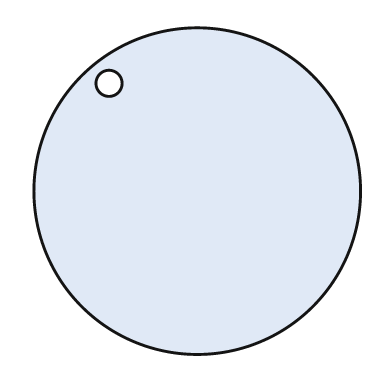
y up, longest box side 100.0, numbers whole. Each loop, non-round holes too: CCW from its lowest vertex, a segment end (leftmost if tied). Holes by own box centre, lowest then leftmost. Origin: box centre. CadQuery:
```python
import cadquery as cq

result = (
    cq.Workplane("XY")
    .moveTo(0.0, 0.0)
    .circle(50.0)
    .moveTo(-27.0, 33.0)
    .circle(4.0)
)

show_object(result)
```